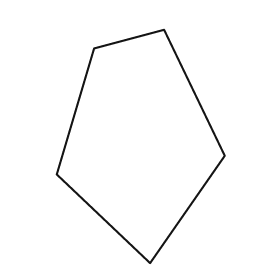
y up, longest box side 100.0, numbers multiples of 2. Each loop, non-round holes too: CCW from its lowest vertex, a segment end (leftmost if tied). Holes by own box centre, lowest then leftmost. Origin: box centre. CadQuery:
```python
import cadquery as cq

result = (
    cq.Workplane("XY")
    .moveTo(4.0, -50.0)
    .lineTo(36.0, -4.0)
    .lineTo(10.0, 50.0)
    .lineTo(-20.0, 42.0)
    .lineTo(-36.0, -12.0)
    .close()
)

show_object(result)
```